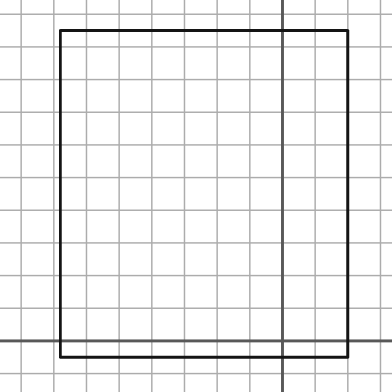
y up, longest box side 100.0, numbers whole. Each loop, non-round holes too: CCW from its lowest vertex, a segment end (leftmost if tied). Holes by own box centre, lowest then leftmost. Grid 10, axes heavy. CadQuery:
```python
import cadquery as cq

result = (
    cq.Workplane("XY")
    .moveTo(-68.0, -5.0)
    .lineTo(20.0, -5.0)
    .lineTo(20.0, 95.0)
    .lineTo(-68.0, 95.0)
    .close()
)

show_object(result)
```